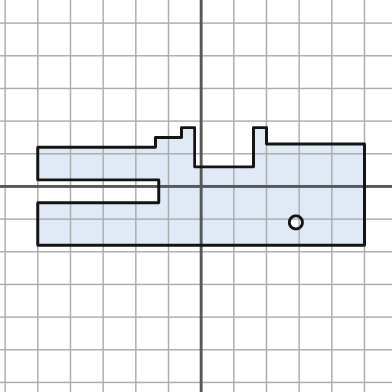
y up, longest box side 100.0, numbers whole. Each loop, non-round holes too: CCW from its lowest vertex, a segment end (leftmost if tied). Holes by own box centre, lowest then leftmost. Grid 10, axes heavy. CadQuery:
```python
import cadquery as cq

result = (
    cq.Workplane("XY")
    .moveTo(-50.0, -18.0)
    .lineTo(50.0, -18.0)
    .lineTo(50.0, 13.0)
    .lineTo(20.0, 13.0)
    .lineTo(20.0, 18.0)
    .lineTo(16.0, 18.0)
    .lineTo(16.0, 6.0)
    .lineTo(-2.0, 6.0)
    .lineTo(-2.0, 18.0)
    .lineTo(-6.0, 18.0)
    .lineTo(-6.0, 15.0)
    .lineTo(-14.0, 15.0)
    .lineTo(-14.0, 12.0)
    .lineTo(-50.0, 12.0)
    .lineTo(-50.0, 2.0)
    .lineTo(-13.0, 2.0)
    .lineTo(-13.0, -5.0)
    .lineTo(-50.0, -5.0)
    .close()
    .moveTo(29.0, -11.0)
    .circle(2.0)
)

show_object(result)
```